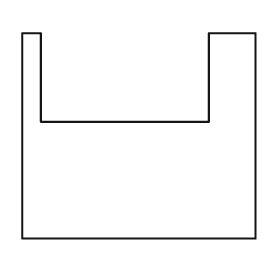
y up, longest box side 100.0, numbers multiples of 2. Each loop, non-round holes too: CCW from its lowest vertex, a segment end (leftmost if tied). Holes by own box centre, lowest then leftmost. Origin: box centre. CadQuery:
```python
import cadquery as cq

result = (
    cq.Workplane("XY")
    .moveTo(-50.0, -44.0)
    .lineTo(50.0, -44.0)
    .lineTo(50.0, 44.0)
    .lineTo(30.0, 44.0)
    .lineTo(30.0, 6.0)
    .lineTo(-42.0, 6.0)
    .lineTo(-42.0, 44.0)
    .lineTo(-50.0, 44.0)
    .close()
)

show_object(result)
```